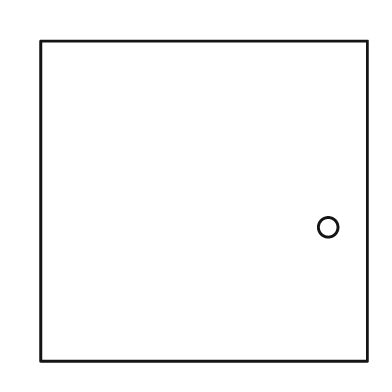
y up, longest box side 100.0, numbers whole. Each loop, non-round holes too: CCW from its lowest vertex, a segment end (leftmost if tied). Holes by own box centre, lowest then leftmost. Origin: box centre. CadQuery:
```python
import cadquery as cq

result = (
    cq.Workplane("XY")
    .moveTo(-50.0, -49.0)
    .lineTo(50.0, -49.0)
    .lineTo(50.0, 49.0)
    .lineTo(-50.0, 49.0)
    .close()
    .moveTo(38.0, -8.0)
    .circle(3.0)
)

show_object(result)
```